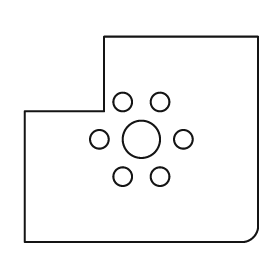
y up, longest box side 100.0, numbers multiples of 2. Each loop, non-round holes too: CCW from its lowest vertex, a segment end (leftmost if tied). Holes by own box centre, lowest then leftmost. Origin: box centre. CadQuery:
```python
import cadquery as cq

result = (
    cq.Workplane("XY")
    .moveTo(-50.0, -44.0)
    .lineTo(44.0, -44.0)
    .threePointArc((48.0, -42.0), (50.0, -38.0))
    .lineTo(50.0, 44.0)
    .lineTo(-16.0, 44.0)
    .lineTo(-16.0, 12.0)
    .lineTo(-50.0, 12.0)
    .close()
    .moveTo(-8.0, -16.0)
    .circle(4.0)
    .moveTo(8.0, -16.0)
    .circle(4.0)
    .moveTo(-18.0, 0.0)
    .circle(4.0)
    .moveTo(0.0, 0.0)
    .circle(8.0)
    .moveTo(18.0, 0.0)
    .circle(4.0)
    .moveTo(-8.0, 16.0)
    .circle(4.0)
    .moveTo(8.0, 16.0)
    .circle(4.0)
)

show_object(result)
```